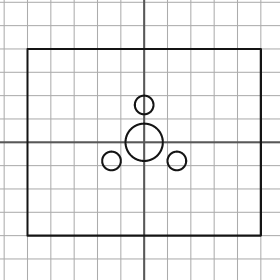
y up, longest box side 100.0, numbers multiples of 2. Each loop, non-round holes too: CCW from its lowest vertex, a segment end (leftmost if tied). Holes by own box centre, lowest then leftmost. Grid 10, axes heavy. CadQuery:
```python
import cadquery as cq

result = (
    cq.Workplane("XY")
    .moveTo(-50.0, -40.0)
    .lineTo(50.0, -40.0)
    .lineTo(50.0, 40.0)
    .lineTo(-50.0, 40.0)
    .close()
    .moveTo(-14.0, -8.0)
    .circle(4.0)
    .moveTo(14.0, -8.0)
    .circle(4.0)
    .moveTo(0.0, 0.0)
    .circle(8.0)
    .moveTo(0.0, 16.0)
    .circle(4.0)
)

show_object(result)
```